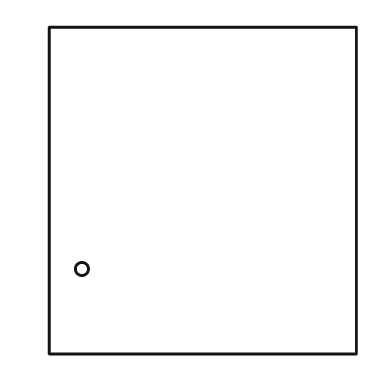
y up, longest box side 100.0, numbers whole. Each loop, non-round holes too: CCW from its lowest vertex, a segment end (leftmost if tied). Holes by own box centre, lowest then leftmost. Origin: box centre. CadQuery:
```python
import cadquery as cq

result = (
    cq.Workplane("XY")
    .moveTo(-47.0, -50.0)
    .lineTo(47.0, -50.0)
    .lineTo(47.0, 50.0)
    .lineTo(-47.0, 50.0)
    .close()
    .moveTo(-37.0, -24.0)
    .circle(2.0)
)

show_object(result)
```